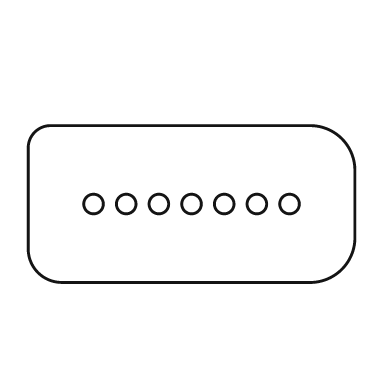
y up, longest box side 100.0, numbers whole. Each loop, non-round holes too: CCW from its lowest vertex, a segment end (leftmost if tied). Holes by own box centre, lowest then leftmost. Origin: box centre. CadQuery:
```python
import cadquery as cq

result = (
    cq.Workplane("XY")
    .moveTo(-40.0, -24.0)
    .lineTo(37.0, -24.0)
    .threePointArc((46.0, -20.0), (50.0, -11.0))
    .lineTo(50.0, 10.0)
    .threePointArc((46.0, 20.0), (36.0, 24.0))
    .lineTo(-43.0, 24.0)
    .threePointArc((-48.0, 22.0), (-50.0, 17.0))
    .lineTo(-50.0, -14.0)
    .threePointArc((-47.0, -21.0), (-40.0, -24.0))
    .close()
    .moveTo(-30.0, 0.0)
    .circle(3.0)
    .moveTo(-20.0, 0.0)
    .circle(3.0)
    .moveTo(-10.0, 0.0)
    .circle(3.0)
    .moveTo(0.0, 0.0)
    .circle(3.0)
    .moveTo(10.0, 0.0)
    .circle(3.0)
    .moveTo(20.0, 0.0)
    .circle(3.0)
    .moveTo(30.0, 0.0)
    .circle(3.0)
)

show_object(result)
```